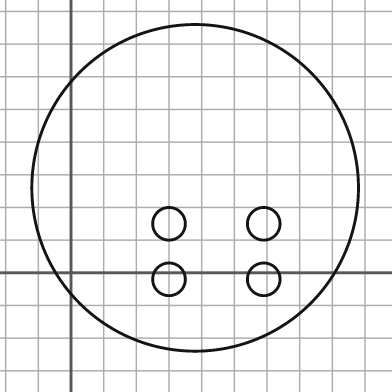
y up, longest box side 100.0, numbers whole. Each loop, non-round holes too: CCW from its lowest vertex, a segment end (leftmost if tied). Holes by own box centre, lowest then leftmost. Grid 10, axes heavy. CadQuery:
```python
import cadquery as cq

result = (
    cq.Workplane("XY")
    .moveTo(38.0, 26.0)
    .circle(50.0)
    .moveTo(30.0, -2.0)
    .circle(5.0)
    .moveTo(59.0, -2.0)
    .circle(5.0)
    .moveTo(30.0, 15.0)
    .circle(5.0)
    .moveTo(59.0, 15.0)
    .circle(5.0)
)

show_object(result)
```